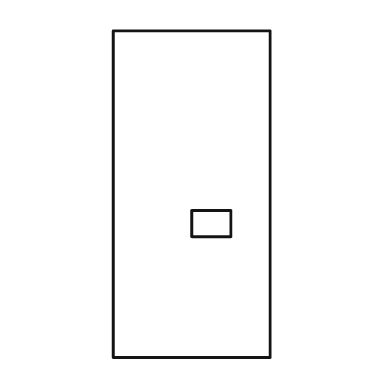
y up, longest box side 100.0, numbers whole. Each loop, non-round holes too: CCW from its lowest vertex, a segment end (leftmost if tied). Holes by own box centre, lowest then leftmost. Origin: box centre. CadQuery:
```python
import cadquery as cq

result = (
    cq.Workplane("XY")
    .moveTo(-24.0, -50.0)
    .lineTo(24.0, -50.0)
    .lineTo(24.0, 50.0)
    .lineTo(-24.0, 50.0)
    .close()
    .moveTo(0.0, -13.0)
    .lineTo(12.0, -13.0)
    .lineTo(12.0, -5.0)
    .lineTo(0.0, -5.0)
    .close()
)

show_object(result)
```